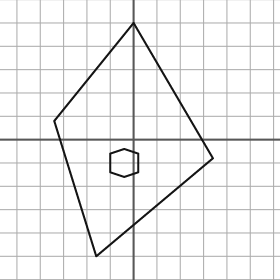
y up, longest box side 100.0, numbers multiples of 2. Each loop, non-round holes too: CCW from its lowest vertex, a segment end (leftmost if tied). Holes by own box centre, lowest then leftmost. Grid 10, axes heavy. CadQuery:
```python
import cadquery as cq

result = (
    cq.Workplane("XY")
    .moveTo(-16.0, -50.0)
    .lineTo(34.0, -8.0)
    .lineTo(0.0, 50.0)
    .lineTo(-34.0, 8.0)
    .close()
    .moveTo(-4.0, -16.0)
    .lineTo(2.0, -14.0)
    .lineTo(2.0, -6.0)
    .lineTo(-4.0, -4.0)
    .lineTo(-10.0, -6.0)
    .lineTo(-10.0, -14.0)
    .close()
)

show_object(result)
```